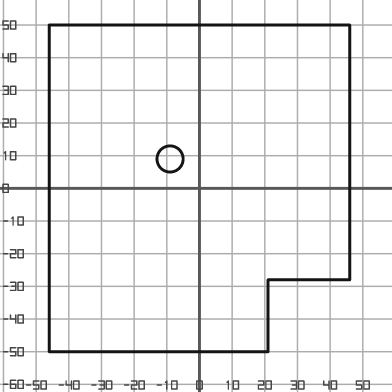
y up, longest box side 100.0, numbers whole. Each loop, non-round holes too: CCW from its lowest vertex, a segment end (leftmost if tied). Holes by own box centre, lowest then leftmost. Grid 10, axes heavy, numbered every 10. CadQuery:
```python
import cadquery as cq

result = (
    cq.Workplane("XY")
    .moveTo(-46.0, -50.0)
    .lineTo(21.0, -50.0)
    .lineTo(21.0, -28.0)
    .lineTo(46.0, -28.0)
    .lineTo(46.0, 50.0)
    .lineTo(-46.0, 50.0)
    .close()
    .moveTo(-9.0, 9.0)
    .circle(4.0)
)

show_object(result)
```